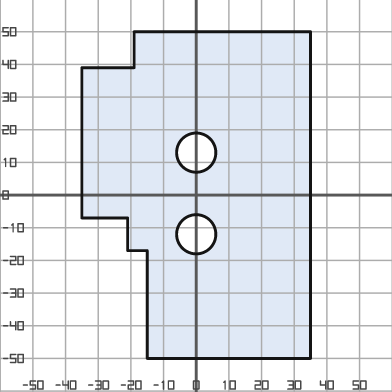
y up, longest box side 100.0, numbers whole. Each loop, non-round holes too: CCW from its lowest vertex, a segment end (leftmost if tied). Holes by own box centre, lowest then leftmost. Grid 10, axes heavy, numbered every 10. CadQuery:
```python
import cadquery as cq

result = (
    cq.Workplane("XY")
    .moveTo(-15.0, -50.0)
    .lineTo(35.0, -50.0)
    .lineTo(35.0, 50.0)
    .lineTo(-19.0, 50.0)
    .lineTo(-19.0, 39.0)
    .lineTo(-35.0, 39.0)
    .lineTo(-35.0, -7.0)
    .lineTo(-21.0, -7.0)
    .lineTo(-21.0, -17.0)
    .lineTo(-15.0, -17.0)
    .close()
    .moveTo(0.0, -12.0)
    .circle(6.0)
    .moveTo(0.0, 13.0)
    .circle(6.0)
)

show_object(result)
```